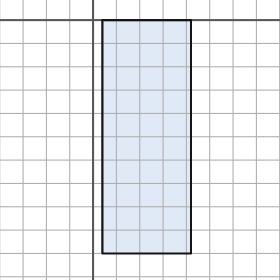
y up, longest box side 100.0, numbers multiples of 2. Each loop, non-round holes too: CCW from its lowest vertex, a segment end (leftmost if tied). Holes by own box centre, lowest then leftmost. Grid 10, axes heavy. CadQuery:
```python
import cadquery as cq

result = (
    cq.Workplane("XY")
    .moveTo(4.0, -100.0)
    .lineTo(42.0, -100.0)
    .lineTo(42.0, 0.0)
    .lineTo(4.0, 0.0)
    .close()
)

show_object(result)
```